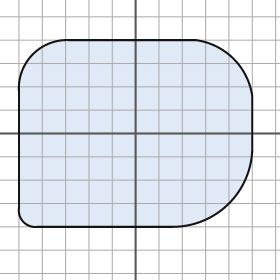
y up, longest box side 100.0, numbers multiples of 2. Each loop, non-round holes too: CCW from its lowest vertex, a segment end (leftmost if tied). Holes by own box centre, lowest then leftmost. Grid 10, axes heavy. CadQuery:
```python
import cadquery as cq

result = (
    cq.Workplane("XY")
    .moveTo(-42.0, -40.0)
    .lineTo(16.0, -40.0)
    .threePointArc((40.0, -30.0), (50.0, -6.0))
    .lineTo(50.0, 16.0)
    .threePointArc((42.0, 32.0), (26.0, 40.0))
    .lineTo(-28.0, 40.0)
    .threePointArc((-44.0, 34.0), (-50.0, 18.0))
    .lineTo(-50.0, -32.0)
    .threePointArc((-48.0, -38.0), (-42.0, -40.0))
    .close()
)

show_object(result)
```